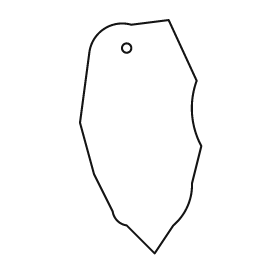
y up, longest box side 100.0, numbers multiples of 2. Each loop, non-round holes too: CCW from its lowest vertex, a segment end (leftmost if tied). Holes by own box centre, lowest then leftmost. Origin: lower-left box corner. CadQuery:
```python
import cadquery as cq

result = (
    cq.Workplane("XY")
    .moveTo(32.0, 0.0)
    .lineTo(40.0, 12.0)
    .threePointArc((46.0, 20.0), (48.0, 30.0))
    .lineTo(52.0, 46.0)
    .threePointArc((48.0, 60.0), (50.0, 74.0))
    .lineTo(38.0, 100.0)
    .lineTo(22.0, 98.0)
    .threePointArc((10.0, 96.0), (4.0, 86.0))
    .lineTo(0.0, 56.0)
    .lineTo(6.0, 34.0)
    .lineTo(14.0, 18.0)
    .threePointArc((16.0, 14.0), (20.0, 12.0))
    .close()
    .moveTo(20.0, 88.0)
    .circle(2.0)
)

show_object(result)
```